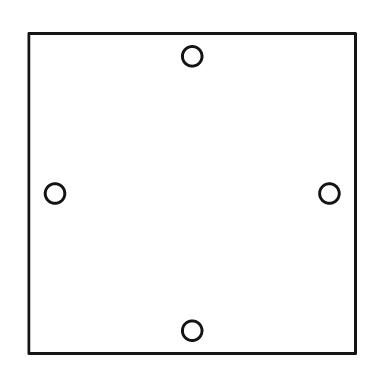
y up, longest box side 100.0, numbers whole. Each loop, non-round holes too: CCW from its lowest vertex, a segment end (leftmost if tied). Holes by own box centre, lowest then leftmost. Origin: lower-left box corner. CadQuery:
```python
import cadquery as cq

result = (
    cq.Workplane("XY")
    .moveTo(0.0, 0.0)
    .lineTo(100.0, 0.0)
    .lineTo(100.0, 98.0)
    .lineTo(0.0, 98.0)
    .close()
    .moveTo(50.0, 7.0)
    .circle(3.0)
    .moveTo(8.0, 49.0)
    .circle(3.0)
    .moveTo(92.0, 49.0)
    .circle(3.0)
    .moveTo(50.0, 91.0)
    .circle(3.0)
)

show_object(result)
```